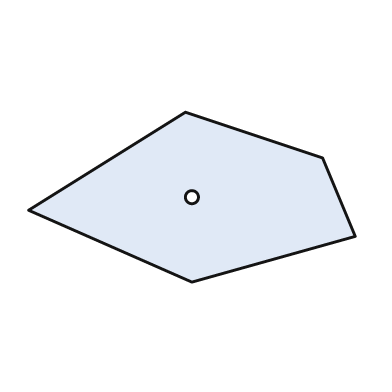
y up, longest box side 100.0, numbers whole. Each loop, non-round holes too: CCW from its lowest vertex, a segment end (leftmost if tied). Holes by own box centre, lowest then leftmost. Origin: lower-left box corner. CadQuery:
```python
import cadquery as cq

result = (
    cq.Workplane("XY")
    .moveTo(50.0, 0.0)
    .lineTo(100.0, 14.0)
    .lineTo(90.0, 38.0)
    .lineTo(48.0, 52.0)
    .lineTo(0.0, 22.0)
    .close()
    .moveTo(50.0, 26.0)
    .circle(2.0)
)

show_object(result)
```